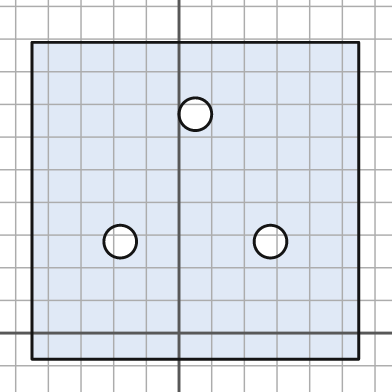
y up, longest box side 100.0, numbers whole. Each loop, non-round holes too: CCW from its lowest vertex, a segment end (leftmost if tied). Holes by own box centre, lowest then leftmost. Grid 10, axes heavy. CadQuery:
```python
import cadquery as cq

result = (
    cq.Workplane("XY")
    .moveTo(-45.0, -8.0)
    .lineTo(55.0, -8.0)
    .lineTo(55.0, 89.0)
    .lineTo(-45.0, 89.0)
    .close()
    .moveTo(-18.0, 28.0)
    .circle(5.0)
    .moveTo(28.0, 28.0)
    .circle(5.0)
    .moveTo(5.0, 67.0)
    .circle(5.0)
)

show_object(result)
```